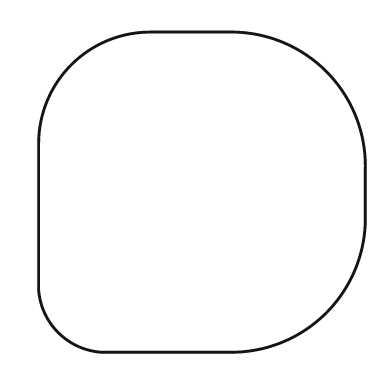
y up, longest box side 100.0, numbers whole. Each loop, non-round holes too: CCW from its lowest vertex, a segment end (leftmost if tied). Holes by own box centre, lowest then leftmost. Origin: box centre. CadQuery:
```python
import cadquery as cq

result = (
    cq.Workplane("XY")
    .moveTo(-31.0, -49.0)
    .lineTo(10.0, -49.0)
    .threePointArc((38.0, -37.0), (50.0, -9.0))
    .lineTo(50.0, 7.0)
    .threePointArc((38.0, 37.0), (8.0, 49.0))
    .lineTo(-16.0, 49.0)
    .threePointArc((-40.0, 39.0), (-50.0, 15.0))
    .lineTo(-50.0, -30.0)
    .threePointArc((-44.0, -43.0), (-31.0, -49.0))
    .close()
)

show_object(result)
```